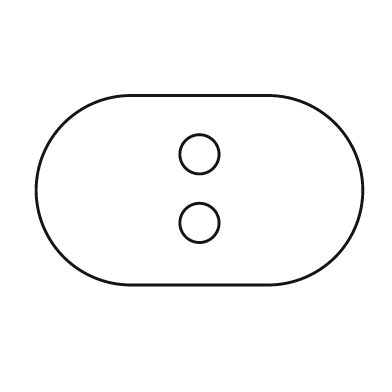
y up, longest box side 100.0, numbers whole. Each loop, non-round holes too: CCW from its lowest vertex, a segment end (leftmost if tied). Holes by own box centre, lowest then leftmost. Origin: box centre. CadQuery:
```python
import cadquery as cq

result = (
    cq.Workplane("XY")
    .moveTo(-21.0, -29.0)
    .lineTo(21.0, -29.0)
    .threePointArc((50.0, 0.0), (21.0, 29.0))
    .lineTo(-21.0, 29.0)
    .threePointArc((-50.0, 0.0), (-21.0, -29.0))
    .close()
    .moveTo(0.0, -10.0)
    .circle(6.0)
    .moveTo(0.0, 11.0)
    .circle(6.0)
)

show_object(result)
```